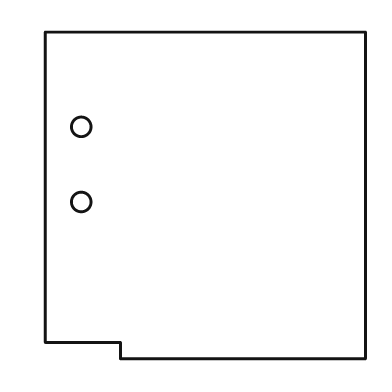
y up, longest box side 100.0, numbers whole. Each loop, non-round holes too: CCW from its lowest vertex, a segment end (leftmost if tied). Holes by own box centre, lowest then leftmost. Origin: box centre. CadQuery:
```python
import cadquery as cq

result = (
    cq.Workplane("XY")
    .moveTo(-26.0, -50.0)
    .lineTo(49.0, -50.0)
    .lineTo(49.0, 50.0)
    .lineTo(-49.0, 50.0)
    .lineTo(-49.0, -45.0)
    .lineTo(-26.0, -45.0)
    .close()
    .moveTo(-38.0, -2.0)
    .circle(3.0)
    .moveTo(-38.0, 21.0)
    .circle(3.0)
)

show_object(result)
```